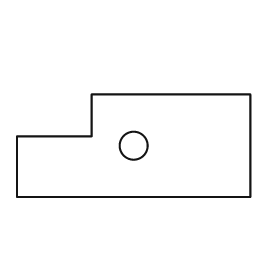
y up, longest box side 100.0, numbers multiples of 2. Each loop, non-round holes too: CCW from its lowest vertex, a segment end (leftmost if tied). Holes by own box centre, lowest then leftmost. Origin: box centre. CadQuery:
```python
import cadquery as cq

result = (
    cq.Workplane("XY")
    .moveTo(-50.0, -22.0)
    .lineTo(50.0, -22.0)
    .lineTo(50.0, 22.0)
    .lineTo(-18.0, 22.0)
    .lineTo(-18.0, 4.0)
    .lineTo(-50.0, 4.0)
    .close()
    .moveTo(0.0, 0.0)
    .circle(6.0)
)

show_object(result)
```